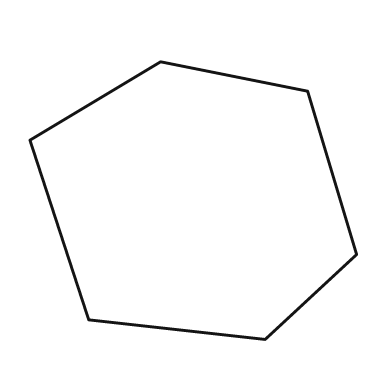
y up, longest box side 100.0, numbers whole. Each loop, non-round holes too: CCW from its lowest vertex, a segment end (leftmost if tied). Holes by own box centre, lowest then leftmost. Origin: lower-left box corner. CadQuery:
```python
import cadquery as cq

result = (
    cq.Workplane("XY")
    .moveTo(72.0, 0.0)
    .lineTo(100.0, 26.0)
    .lineTo(85.0, 76.0)
    .lineTo(40.0, 85.0)
    .lineTo(0.0, 61.0)
    .lineTo(18.0, 6.0)
    .close()
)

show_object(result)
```